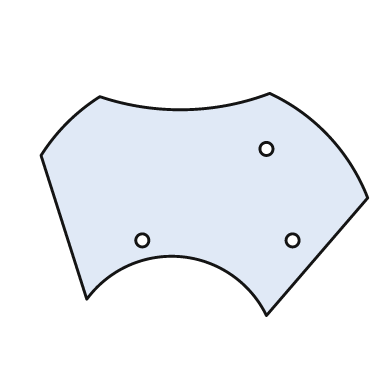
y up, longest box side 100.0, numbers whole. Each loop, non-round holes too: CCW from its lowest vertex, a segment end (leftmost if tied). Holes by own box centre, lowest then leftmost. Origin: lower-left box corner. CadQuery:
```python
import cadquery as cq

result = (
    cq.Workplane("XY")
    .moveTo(69.0, 0.0)
    .lineTo(100.0, 36.0)
    .threePointArc((88.0, 55.0), (70.0, 68.0))
    .threePointArc((44.0, 63.0), (18.0, 67.0))
    .threePointArc((8.0, 59.0), (0.0, 49.0))
    .lineTo(14.0, 5.0)
    .threePointArc((43.0, 18.0), (69.0, 0.0))
    .close()
    .moveTo(31.0, 23.0)
    .circle(2.0)
    .moveTo(77.0, 23.0)
    .circle(2.0)
    .moveTo(69.0, 51.0)
    .circle(2.0)
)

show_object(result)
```